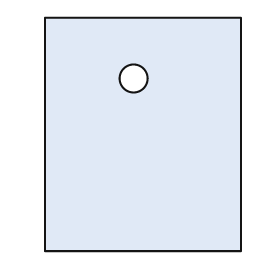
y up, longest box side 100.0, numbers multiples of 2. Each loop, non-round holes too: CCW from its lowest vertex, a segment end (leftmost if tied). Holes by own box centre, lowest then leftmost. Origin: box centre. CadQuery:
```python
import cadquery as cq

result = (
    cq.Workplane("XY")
    .moveTo(-42.0, -50.0)
    .lineTo(42.0, -50.0)
    .lineTo(42.0, 50.0)
    .lineTo(-42.0, 50.0)
    .close()
    .moveTo(-4.0, 24.0)
    .circle(6.0)
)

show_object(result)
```